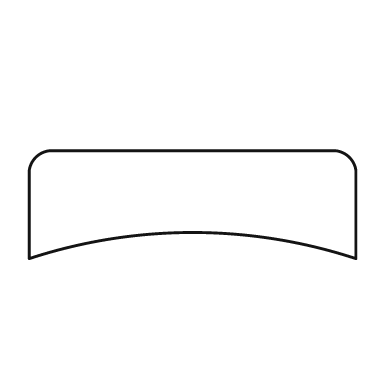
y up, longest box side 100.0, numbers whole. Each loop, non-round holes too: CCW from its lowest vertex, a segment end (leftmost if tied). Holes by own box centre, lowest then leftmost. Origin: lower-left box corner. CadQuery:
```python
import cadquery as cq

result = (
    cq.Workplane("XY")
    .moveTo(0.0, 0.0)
    .threePointArc((50.0, 8.0), (100.0, 0.0))
    .lineTo(100.0, 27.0)
    .threePointArc((98.0, 31.0), (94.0, 33.0))
    .lineTo(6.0, 33.0)
    .threePointArc((2.0, 31.0), (0.0, 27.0))
    .close()
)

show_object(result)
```